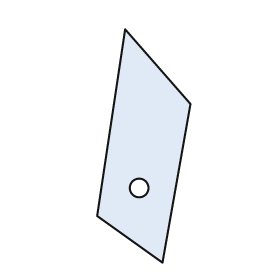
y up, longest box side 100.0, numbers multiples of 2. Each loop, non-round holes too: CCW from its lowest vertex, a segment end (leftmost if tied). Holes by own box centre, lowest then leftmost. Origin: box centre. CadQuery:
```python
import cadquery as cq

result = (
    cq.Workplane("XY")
    .moveTo(8.0, -50.0)
    .lineTo(20.0, 18.0)
    .lineTo(-8.0, 50.0)
    .lineTo(-20.0, -30.0)
    .close()
    .moveTo(-2.0, -18.0)
    .circle(4.0)
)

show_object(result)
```